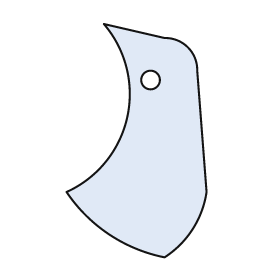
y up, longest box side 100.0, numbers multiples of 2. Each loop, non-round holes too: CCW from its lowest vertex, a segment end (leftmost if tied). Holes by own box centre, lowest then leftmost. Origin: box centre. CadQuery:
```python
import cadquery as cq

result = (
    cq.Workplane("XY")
    .moveTo(12.0, -50.0)
    .threePointArc((24.0, -38.0), (30.0, -22.0))
    .lineTo(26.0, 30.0)
    .threePointArc((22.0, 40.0), (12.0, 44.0))
    .lineTo(-14.0, 50.0)
    .threePointArc((-4.0, 10.0), (-30.0, -22.0))
    .threePointArc((-12.0, -40.0), (12.0, -50.0))
    .close()
    .moveTo(6.0, 26.0)
    .circle(4.0)
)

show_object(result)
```